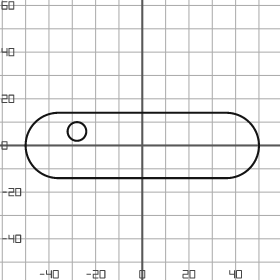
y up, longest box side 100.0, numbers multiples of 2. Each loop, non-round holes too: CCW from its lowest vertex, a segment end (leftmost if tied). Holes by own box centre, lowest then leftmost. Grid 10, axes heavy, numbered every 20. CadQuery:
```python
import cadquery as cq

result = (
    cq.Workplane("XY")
    .moveTo(-36.0, -14.0)
    .lineTo(36.0, -14.0)
    .threePointArc((50.0, 0.0), (36.0, 14.0))
    .lineTo(-36.0, 14.0)
    .threePointArc((-50.0, 0.0), (-36.0, -14.0))
    .close()
    .moveTo(-28.0, 6.0)
    .circle(4.0)
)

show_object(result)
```